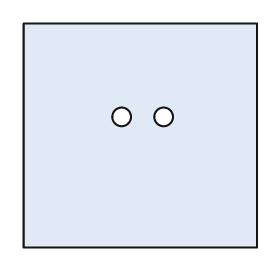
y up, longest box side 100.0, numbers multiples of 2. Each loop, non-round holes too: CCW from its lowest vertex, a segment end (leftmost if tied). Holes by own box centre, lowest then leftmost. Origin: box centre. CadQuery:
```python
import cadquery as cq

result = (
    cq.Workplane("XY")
    .moveTo(-50.0, -48.0)
    .lineTo(50.0, -48.0)
    .lineTo(50.0, 48.0)
    .lineTo(-50.0, 48.0)
    .close()
    .moveTo(-8.0, 8.0)
    .circle(4.0)
    .moveTo(10.0, 8.0)
    .circle(4.0)
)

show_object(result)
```